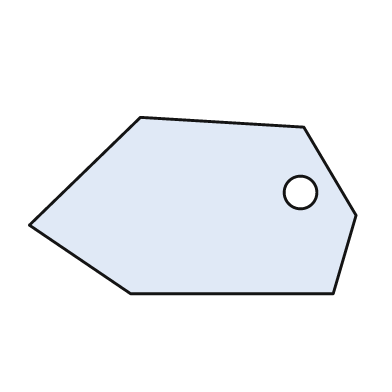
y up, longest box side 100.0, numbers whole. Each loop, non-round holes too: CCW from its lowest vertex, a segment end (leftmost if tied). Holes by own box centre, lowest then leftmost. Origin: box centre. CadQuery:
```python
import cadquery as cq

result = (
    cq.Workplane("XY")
    .moveTo(-19.0, -27.0)
    .lineTo(43.0, -27.0)
    .lineTo(50.0, -3.0)
    .lineTo(34.0, 24.0)
    .lineTo(-16.0, 27.0)
    .lineTo(-50.0, -6.0)
    .close()
    .moveTo(33.0, 4.0)
    .circle(5.0)
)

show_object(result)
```